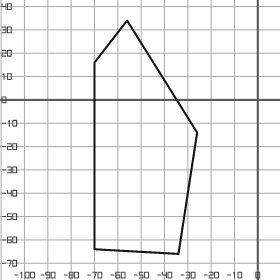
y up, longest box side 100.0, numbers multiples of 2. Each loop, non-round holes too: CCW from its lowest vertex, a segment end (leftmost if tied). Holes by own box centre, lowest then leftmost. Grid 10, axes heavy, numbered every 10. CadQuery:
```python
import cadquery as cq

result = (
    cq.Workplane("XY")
    .moveTo(-34.0, -66.0)
    .lineTo(-26.0, -14.0)
    .lineTo(-56.0, 34.0)
    .lineTo(-70.0, 16.0)
    .lineTo(-70.0, -64.0)
    .close()
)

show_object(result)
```